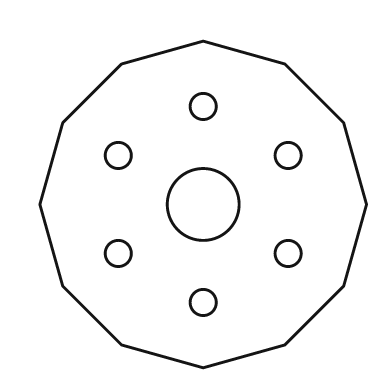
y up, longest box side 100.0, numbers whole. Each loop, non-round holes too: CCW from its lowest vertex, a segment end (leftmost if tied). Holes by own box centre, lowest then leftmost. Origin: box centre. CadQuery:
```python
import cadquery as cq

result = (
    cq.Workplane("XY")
    .moveTo(0.0, -50.0)
    .lineTo(25.0, -43.0)
    .lineTo(43.0, -25.0)
    .lineTo(50.0, 0.0)
    .lineTo(43.0, 25.0)
    .lineTo(25.0, 43.0)
    .lineTo(0.0, 50.0)
    .lineTo(-25.0, 43.0)
    .lineTo(-43.0, 25.0)
    .lineTo(-50.0, 0.0)
    .lineTo(-43.0, -25.0)
    .lineTo(-25.0, -43.0)
    .close()
    .moveTo(0.0, -30.0)
    .circle(4.0)
    .moveTo(-26.0, -15.0)
    .circle(4.0)
    .moveTo(26.0, -15.0)
    .circle(4.0)
    .moveTo(0.0, 0.0)
    .circle(11.0)
    .moveTo(-26.0, 15.0)
    .circle(4.0)
    .moveTo(26.0, 15.0)
    .circle(4.0)
    .moveTo(0.0, 30.0)
    .circle(4.0)
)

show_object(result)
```